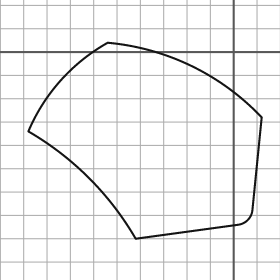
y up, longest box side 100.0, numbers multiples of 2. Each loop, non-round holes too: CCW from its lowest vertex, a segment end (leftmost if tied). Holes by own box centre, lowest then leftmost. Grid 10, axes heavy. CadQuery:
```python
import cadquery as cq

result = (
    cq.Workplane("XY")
    .moveTo(-42.0, -80.0)
    .lineTo(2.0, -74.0)
    .threePointArc((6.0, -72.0), (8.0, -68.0))
    .lineTo(12.0, -28.0)
    .threePointArc((-18.0, -6.0), (-54.0, 4.0))
    .threePointArc((-74.0, -12.0), (-88.0, -34.0))
    .threePointArc((-62.0, -54.0), (-42.0, -80.0))
    .close()
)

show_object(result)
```